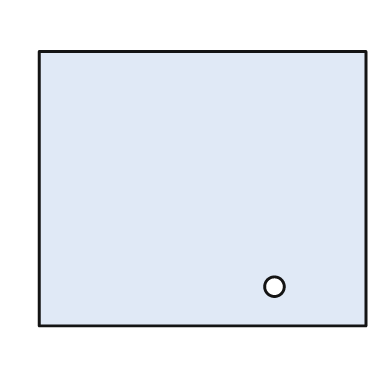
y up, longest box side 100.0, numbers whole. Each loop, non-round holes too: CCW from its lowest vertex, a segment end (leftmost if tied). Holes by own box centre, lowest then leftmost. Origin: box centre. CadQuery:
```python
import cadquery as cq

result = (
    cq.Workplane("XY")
    .moveTo(-50.0, -42.0)
    .lineTo(50.0, -42.0)
    .lineTo(50.0, 42.0)
    .lineTo(-50.0, 42.0)
    .close()
    .moveTo(22.0, -30.0)
    .circle(3.0)
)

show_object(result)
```